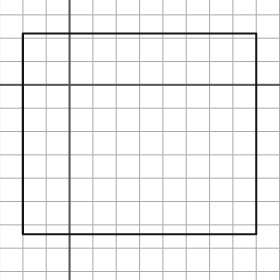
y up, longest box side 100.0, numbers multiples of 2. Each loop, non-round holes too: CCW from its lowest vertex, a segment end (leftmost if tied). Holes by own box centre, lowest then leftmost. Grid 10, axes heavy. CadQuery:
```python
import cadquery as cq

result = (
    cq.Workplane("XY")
    .moveTo(-20.0, -64.0)
    .lineTo(80.0, -64.0)
    .lineTo(80.0, 22.0)
    .lineTo(-20.0, 22.0)
    .close()
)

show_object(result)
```